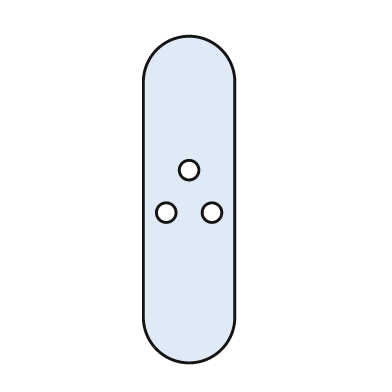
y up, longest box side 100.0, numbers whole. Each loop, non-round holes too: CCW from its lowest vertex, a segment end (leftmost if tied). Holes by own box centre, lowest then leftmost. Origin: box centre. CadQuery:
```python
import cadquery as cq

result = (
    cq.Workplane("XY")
    .moveTo(-14.0, -36.0)
    .threePointArc((0.0, -50.0), (14.0, -36.0))
    .lineTo(14.0, 36.0)
    .threePointArc((0.0, 50.0), (-14.0, 36.0))
    .close()
    .moveTo(-7.0, -4.0)
    .circle(3.0)
    .moveTo(7.0, -4.0)
    .circle(3.0)
    .moveTo(0.0, 9.0)
    .circle(3.0)
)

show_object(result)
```